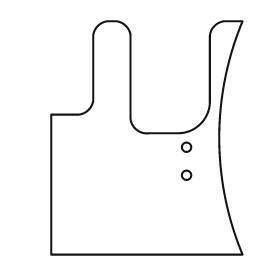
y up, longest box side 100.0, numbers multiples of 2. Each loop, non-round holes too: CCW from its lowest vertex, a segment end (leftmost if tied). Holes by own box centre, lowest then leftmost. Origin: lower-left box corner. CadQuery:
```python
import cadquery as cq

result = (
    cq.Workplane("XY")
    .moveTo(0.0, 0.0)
    .lineTo(82.0, 0.0)
    .threePointArc((72.0, 50.0), (82.0, 100.0))
    .lineTo(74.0, 100.0)
    .threePointArc((70.0, 98.0), (68.0, 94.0))
    .lineTo(68.0, 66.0)
    .threePointArc((64.0, 56.0), (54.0, 52.0))
    .lineTo(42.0, 52.0)
    .threePointArc((36.0, 54.0), (34.0, 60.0))
    .lineTo(34.0, 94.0)
    .threePointArc((32.0, 98.0), (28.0, 100.0))
    .lineTo(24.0, 100.0)
    .threePointArc((20.0, 98.0), (18.0, 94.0))
    .lineTo(18.0, 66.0)
    .threePointArc((16.0, 62.0), (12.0, 60.0))
    .lineTo(0.0, 60.0)
    .close()
    .moveTo(58.0, 34.0)
    .circle(2.0)
    .moveTo(58.0, 46.0)
    .circle(2.0)
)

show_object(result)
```